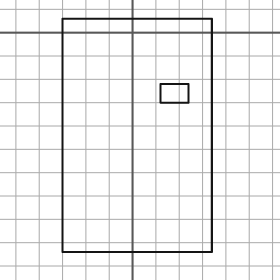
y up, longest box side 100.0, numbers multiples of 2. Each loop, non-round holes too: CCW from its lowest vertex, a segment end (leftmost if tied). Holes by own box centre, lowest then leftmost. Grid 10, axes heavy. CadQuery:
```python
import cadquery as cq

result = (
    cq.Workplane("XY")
    .moveTo(-30.0, -94.0)
    .lineTo(34.0, -94.0)
    .lineTo(34.0, 6.0)
    .lineTo(-30.0, 6.0)
    .close()
    .moveTo(12.0, -30.0)
    .lineTo(24.0, -30.0)
    .lineTo(24.0, -22.0)
    .lineTo(12.0, -22.0)
    .close()
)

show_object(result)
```